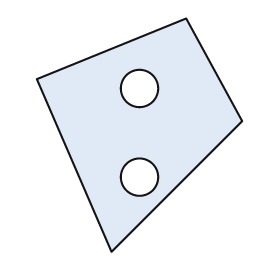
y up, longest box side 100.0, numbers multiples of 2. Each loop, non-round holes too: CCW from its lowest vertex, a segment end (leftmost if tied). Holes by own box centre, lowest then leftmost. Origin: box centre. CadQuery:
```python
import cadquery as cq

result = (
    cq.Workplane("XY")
    .moveTo(-12.0, -50.0)
    .lineTo(44.0, 6.0)
    .lineTo(20.0, 50.0)
    .lineTo(-44.0, 24.0)
    .close()
    .moveTo(0.0, -18.0)
    .circle(8.0)
    .moveTo(0.0, 20.0)
    .circle(8.0)
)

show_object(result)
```